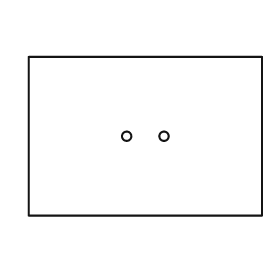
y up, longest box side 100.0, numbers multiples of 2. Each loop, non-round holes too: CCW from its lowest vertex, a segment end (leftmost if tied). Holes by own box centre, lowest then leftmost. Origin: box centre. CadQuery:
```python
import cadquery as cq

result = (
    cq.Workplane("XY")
    .moveTo(-50.0, -34.0)
    .lineTo(50.0, -34.0)
    .lineTo(50.0, 34.0)
    .lineTo(-50.0, 34.0)
    .close()
    .moveTo(-8.0, 0.0)
    .circle(2.0)
    .moveTo(8.0, 0.0)
    .circle(2.0)
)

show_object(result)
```